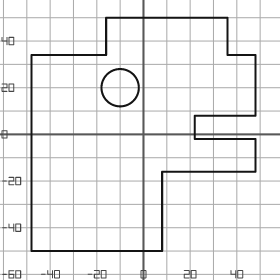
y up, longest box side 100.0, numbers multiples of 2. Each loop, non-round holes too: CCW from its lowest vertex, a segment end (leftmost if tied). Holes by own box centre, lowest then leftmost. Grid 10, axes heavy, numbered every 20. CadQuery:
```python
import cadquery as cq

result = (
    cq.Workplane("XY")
    .moveTo(-48.0, -50.0)
    .lineTo(8.0, -50.0)
    .lineTo(8.0, -16.0)
    .lineTo(48.0, -16.0)
    .lineTo(48.0, -2.0)
    .lineTo(22.0, -2.0)
    .lineTo(22.0, 8.0)
    .lineTo(48.0, 8.0)
    .lineTo(48.0, 34.0)
    .lineTo(36.0, 34.0)
    .lineTo(36.0, 50.0)
    .lineTo(-16.0, 50.0)
    .lineTo(-16.0, 34.0)
    .lineTo(-48.0, 34.0)
    .close()
    .moveTo(-10.0, 20.0)
    .circle(8.0)
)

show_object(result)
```